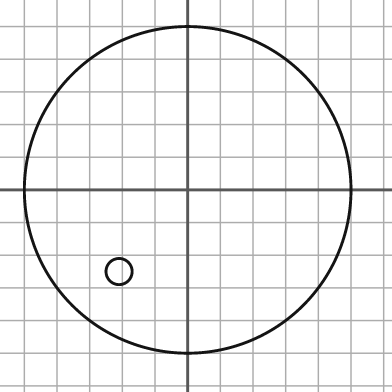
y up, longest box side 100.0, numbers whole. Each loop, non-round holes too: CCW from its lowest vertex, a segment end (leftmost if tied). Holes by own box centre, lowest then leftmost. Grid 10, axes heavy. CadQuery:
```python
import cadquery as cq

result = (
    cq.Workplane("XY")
    .moveTo(0.0, 0.0)
    .circle(50.0)
    .moveTo(-21.0, -25.0)
    .circle(4.0)
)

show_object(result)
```